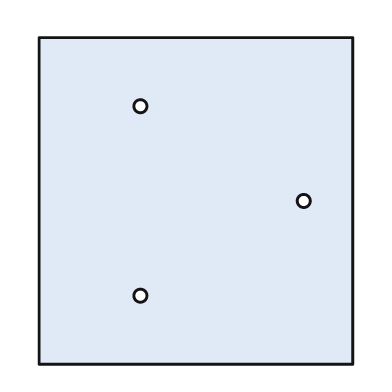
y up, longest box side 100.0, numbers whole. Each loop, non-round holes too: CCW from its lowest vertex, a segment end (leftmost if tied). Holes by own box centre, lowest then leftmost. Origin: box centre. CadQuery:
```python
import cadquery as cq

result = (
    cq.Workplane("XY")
    .moveTo(-48.0, -50.0)
    .lineTo(48.0, -50.0)
    .lineTo(48.0, 50.0)
    .lineTo(-48.0, 50.0)
    .close()
    .moveTo(-17.0, -29.0)
    .circle(2.0)
    .moveTo(33.0, 0.0)
    .circle(2.0)
    .moveTo(-17.0, 29.0)
    .circle(2.0)
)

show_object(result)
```